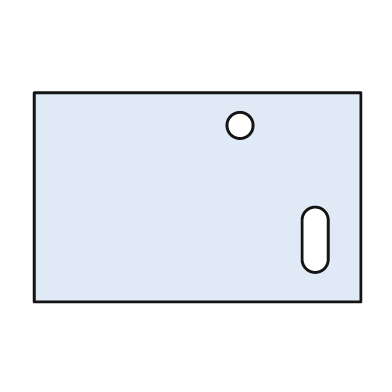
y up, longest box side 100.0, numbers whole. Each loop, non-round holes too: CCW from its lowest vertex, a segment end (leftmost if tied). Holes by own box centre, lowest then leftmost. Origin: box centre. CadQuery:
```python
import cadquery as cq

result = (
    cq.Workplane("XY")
    .moveTo(-50.0, -32.0)
    .lineTo(50.0, -32.0)
    .lineTo(50.0, 32.0)
    .lineTo(-50.0, 32.0)
    .close()
    .moveTo(32.0, -19.0)
    .threePointArc((36.0, -23.0), (40.0, -19.0))
    .lineTo(40.0, -7.0)
    .threePointArc((36.0, -3.0), (32.0, -7.0))
    .close()
    .moveTo(13.0, 22.0)
    .circle(4.0)
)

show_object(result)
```